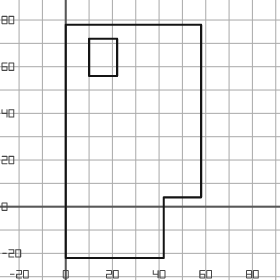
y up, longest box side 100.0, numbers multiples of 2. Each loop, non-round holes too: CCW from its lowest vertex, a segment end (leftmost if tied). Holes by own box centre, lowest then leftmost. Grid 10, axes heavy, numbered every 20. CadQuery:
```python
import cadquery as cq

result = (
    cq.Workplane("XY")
    .moveTo(0.0, -22.0)
    .lineTo(42.0, -22.0)
    .lineTo(42.0, 4.0)
    .lineTo(58.0, 4.0)
    .lineTo(58.0, 78.0)
    .lineTo(0.0, 78.0)
    .close()
    .moveTo(10.0, 56.0)
    .lineTo(22.0, 56.0)
    .lineTo(22.0, 72.0)
    .lineTo(10.0, 72.0)
    .close()
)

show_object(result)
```